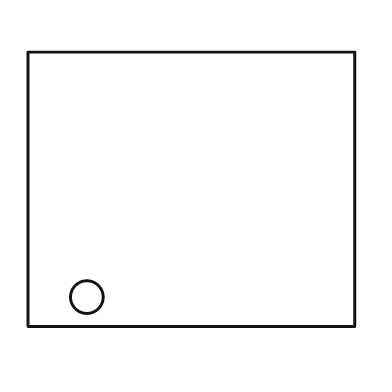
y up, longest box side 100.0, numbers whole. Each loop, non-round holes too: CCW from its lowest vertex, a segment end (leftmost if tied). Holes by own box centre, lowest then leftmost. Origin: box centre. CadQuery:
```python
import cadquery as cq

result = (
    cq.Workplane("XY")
    .moveTo(-50.0, -42.0)
    .lineTo(50.0, -42.0)
    .lineTo(50.0, 42.0)
    .lineTo(-50.0, 42.0)
    .close()
    .moveTo(-32.0, -33.0)
    .circle(5.0)
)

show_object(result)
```